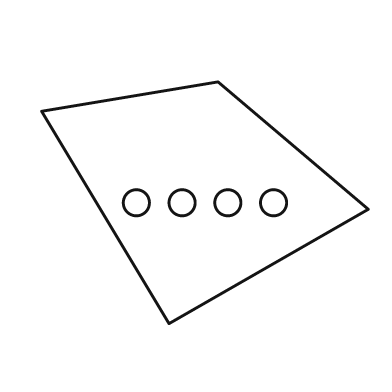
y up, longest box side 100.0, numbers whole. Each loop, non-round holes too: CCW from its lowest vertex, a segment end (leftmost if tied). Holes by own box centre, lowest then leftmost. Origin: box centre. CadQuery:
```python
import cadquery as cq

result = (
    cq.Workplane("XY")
    .moveTo(-11.0, -37.0)
    .lineTo(50.0, -2.0)
    .lineTo(4.0, 37.0)
    .lineTo(-50.0, 28.0)
    .close()
    .moveTo(-21.0, 0.0)
    .circle(4.0)
    .moveTo(-7.0, 0.0)
    .circle(4.0)
    .moveTo(7.0, 0.0)
    .circle(4.0)
    .moveTo(21.0, 0.0)
    .circle(4.0)
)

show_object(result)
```